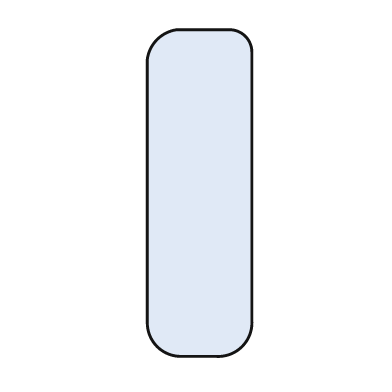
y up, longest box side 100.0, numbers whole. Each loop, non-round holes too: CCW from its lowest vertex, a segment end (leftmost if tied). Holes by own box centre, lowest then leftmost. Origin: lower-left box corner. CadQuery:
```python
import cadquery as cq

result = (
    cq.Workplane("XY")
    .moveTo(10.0, 0.0)
    .lineTo(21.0, 0.0)
    .threePointArc((29.0, 3.0), (32.0, 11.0))
    .lineTo(32.0, 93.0)
    .threePointArc((30.0, 98.0), (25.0, 100.0))
    .lineTo(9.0, 100.0)
    .threePointArc((3.0, 97.0), (0.0, 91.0))
    .lineTo(0.0, 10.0)
    .threePointArc((3.0, 3.0), (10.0, 0.0))
    .close()
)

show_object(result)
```